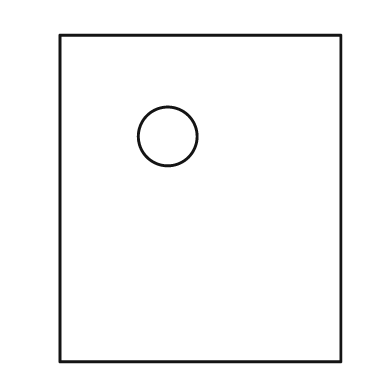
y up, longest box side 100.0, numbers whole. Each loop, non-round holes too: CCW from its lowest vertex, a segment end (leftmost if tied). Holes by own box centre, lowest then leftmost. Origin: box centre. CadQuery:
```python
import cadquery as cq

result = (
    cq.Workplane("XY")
    .moveTo(-43.0, -50.0)
    .lineTo(43.0, -50.0)
    .lineTo(43.0, 50.0)
    .lineTo(-43.0, 50.0)
    .close()
    .moveTo(-10.0, 19.0)
    .circle(9.0)
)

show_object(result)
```